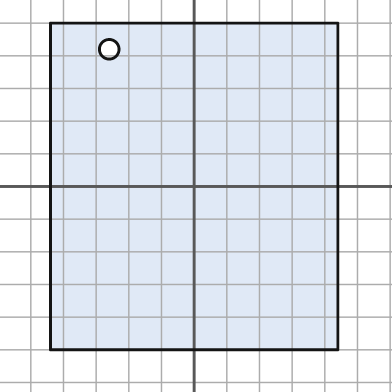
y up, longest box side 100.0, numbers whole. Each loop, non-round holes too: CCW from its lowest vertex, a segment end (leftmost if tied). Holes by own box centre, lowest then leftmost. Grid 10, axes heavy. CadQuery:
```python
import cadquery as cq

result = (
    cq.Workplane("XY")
    .moveTo(-44.0, -50.0)
    .lineTo(44.0, -50.0)
    .lineTo(44.0, 50.0)
    .lineTo(-44.0, 50.0)
    .close()
    .moveTo(-26.0, 42.0)
    .circle(3.0)
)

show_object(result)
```